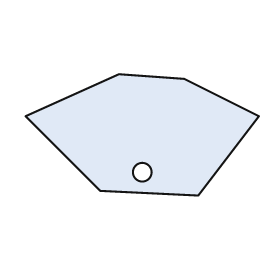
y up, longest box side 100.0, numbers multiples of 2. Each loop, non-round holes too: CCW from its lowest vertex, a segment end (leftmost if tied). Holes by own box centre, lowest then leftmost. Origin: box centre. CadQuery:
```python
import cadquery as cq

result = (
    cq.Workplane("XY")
    .moveTo(24.0, -26.0)
    .lineTo(50.0, 8.0)
    .lineTo(18.0, 24.0)
    .lineTo(-10.0, 26.0)
    .lineTo(-50.0, 8.0)
    .lineTo(-18.0, -24.0)
    .close()
    .moveTo(0.0, -16.0)
    .circle(4.0)
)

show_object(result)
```